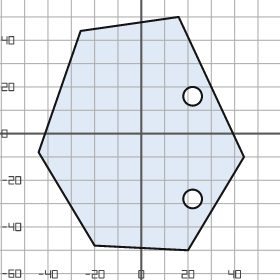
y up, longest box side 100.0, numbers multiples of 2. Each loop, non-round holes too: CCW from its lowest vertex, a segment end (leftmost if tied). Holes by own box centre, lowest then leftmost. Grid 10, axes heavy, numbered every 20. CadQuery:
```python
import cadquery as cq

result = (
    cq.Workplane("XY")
    .moveTo(20.0, -50.0)
    .lineTo(44.0, -10.0)
    .lineTo(16.0, 50.0)
    .lineTo(-26.0, 44.0)
    .lineTo(-44.0, -8.0)
    .lineTo(-20.0, -48.0)
    .close()
    .moveTo(22.0, -28.0)
    .circle(4.0)
    .moveTo(22.0, 16.0)
    .circle(4.0)
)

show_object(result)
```